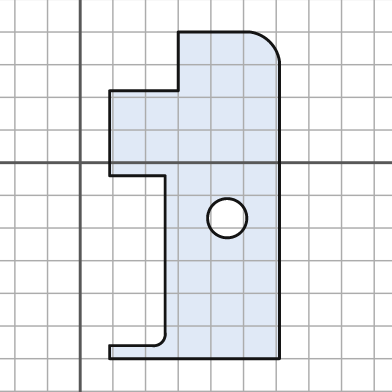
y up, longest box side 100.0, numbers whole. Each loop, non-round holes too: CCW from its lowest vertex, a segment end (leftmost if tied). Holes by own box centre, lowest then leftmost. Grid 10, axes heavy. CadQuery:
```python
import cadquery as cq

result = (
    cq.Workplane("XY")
    .moveTo(9.0, -60.0)
    .lineTo(61.0, -60.0)
    .lineTo(61.0, 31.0)
    .threePointArc((58.0, 37.0), (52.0, 40.0))
    .lineTo(30.0, 40.0)
    .lineTo(30.0, 22.0)
    .lineTo(9.0, 22.0)
    .lineTo(9.0, -4.0)
    .lineTo(26.0, -4.0)
    .lineTo(26.0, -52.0)
    .threePointArc((25.0, -55.0), (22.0, -56.0))
    .lineTo(9.0, -56.0)
    .close()
    .moveTo(45.0, -17.0)
    .circle(6.0)
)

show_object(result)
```